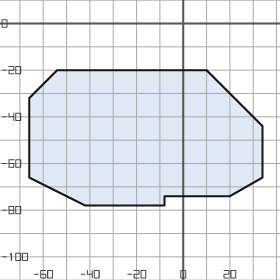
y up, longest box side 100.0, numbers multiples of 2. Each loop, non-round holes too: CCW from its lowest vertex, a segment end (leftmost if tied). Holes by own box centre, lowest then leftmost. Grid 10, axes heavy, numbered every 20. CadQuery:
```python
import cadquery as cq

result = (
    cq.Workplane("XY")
    .moveTo(-42.0, -78.0)
    .lineTo(-8.0, -78.0)
    .lineTo(-8.0, -74.0)
    .lineTo(20.0, -74.0)
    .lineTo(34.0, -66.0)
    .lineTo(34.0, -44.0)
    .lineTo(10.0, -20.0)
    .lineTo(-54.0, -20.0)
    .lineTo(-66.0, -32.0)
    .lineTo(-66.0, -66.0)
    .close()
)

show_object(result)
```